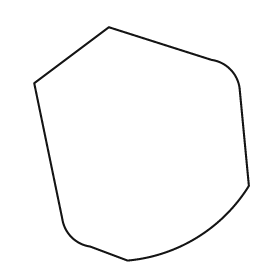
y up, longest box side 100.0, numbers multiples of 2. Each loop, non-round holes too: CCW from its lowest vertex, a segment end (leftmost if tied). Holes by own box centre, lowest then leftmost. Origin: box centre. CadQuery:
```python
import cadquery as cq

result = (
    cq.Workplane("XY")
    .moveTo(-6.0, -50.0)
    .threePointArc((24.0, -40.0), (46.0, -18.0))
    .lineTo(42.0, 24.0)
    .threePointArc((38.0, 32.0), (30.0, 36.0))
    .lineTo(-14.0, 50.0)
    .lineTo(-46.0, 26.0)
    .lineTo(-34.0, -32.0)
    .threePointArc((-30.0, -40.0), (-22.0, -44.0))
    .close()
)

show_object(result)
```